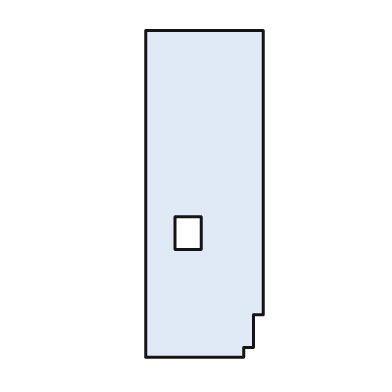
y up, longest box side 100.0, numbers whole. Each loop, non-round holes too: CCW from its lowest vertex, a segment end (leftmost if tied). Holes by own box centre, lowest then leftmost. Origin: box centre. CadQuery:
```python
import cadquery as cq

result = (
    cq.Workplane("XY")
    .moveTo(-18.0, -50.0)
    .lineTo(12.0, -50.0)
    .lineTo(12.0, -47.0)
    .lineTo(15.0, -47.0)
    .lineTo(15.0, -37.0)
    .lineTo(18.0, -37.0)
    .lineTo(18.0, 50.0)
    .lineTo(-18.0, 50.0)
    .close()
    .moveTo(-9.0, -17.0)
    .lineTo(-1.0, -17.0)
    .lineTo(-1.0, -7.0)
    .lineTo(-9.0, -7.0)
    .close()
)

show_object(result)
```